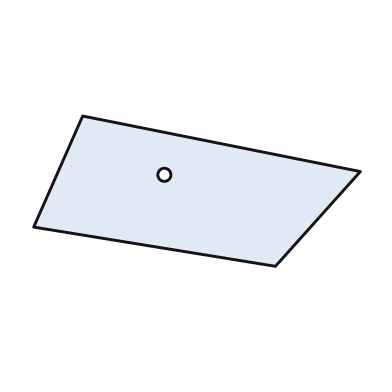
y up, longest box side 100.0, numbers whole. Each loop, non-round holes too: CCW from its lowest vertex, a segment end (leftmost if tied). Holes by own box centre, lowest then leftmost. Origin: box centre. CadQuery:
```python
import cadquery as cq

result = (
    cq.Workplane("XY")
    .moveTo(24.0, -23.0)
    .lineTo(50.0, 6.0)
    .lineTo(-35.0, 23.0)
    .lineTo(-50.0, -11.0)
    .close()
    .moveTo(-10.0, 5.0)
    .circle(2.0)
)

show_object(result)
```